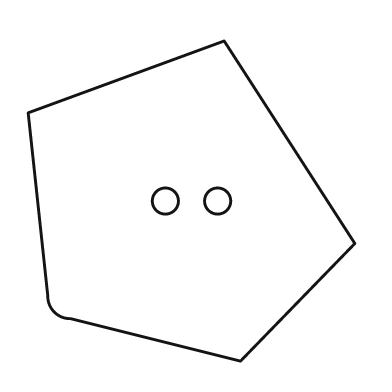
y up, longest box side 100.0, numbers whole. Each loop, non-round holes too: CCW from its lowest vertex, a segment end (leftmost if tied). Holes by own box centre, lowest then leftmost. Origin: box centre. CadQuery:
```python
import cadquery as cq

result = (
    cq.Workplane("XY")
    .moveTo(15.0, -49.0)
    .lineTo(50.0, -13.0)
    .lineTo(10.0, 49.0)
    .lineTo(-50.0, 27.0)
    .lineTo(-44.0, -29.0)
    .threePointArc((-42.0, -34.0), (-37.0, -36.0))
    .close()
    .moveTo(-8.0, 0.0)
    .circle(4.0)
    .moveTo(8.0, 0.0)
    .circle(4.0)
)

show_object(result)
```